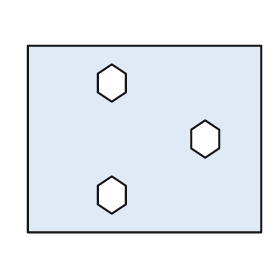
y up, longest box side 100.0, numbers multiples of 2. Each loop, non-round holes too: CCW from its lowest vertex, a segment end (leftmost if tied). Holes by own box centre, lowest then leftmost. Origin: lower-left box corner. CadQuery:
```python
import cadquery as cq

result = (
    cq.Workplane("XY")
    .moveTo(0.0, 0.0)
    .lineTo(100.0, 0.0)
    .lineTo(100.0, 80.0)
    .lineTo(0.0, 80.0)
    .close()
    .moveTo(36.0, 8.0)
    .lineTo(42.0, 12.0)
    .lineTo(42.0, 20.0)
    .lineTo(36.0, 24.0)
    .lineTo(30.0, 20.0)
    .lineTo(30.0, 12.0)
    .close()
    .moveTo(76.0, 32.0)
    .lineTo(82.0, 36.0)
    .lineTo(82.0, 44.0)
    .lineTo(76.0, 48.0)
    .lineTo(70.0, 44.0)
    .lineTo(70.0, 36.0)
    .close()
    .moveTo(36.0, 56.0)
    .lineTo(42.0, 60.0)
    .lineTo(42.0, 68.0)
    .lineTo(36.0, 72.0)
    .lineTo(30.0, 68.0)
    .lineTo(30.0, 60.0)
    .close()
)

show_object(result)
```